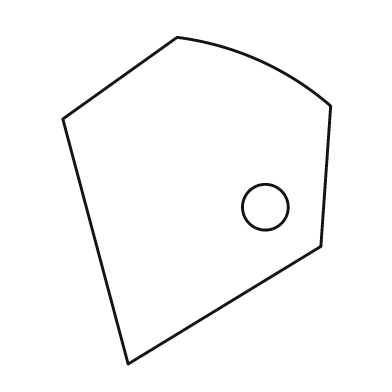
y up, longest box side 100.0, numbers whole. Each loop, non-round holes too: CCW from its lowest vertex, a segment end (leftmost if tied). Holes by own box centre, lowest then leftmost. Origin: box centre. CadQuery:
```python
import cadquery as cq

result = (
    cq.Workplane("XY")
    .moveTo(-21.0, -50.0)
    .lineTo(38.0, -14.0)
    .lineTo(41.0, 29.0)
    .threePointArc((19.0, 43.0), (-6.0, 50.0))
    .lineTo(-41.0, 25.0)
    .close()
    .moveTo(21.0, -2.0)
    .circle(7.0)
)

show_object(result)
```